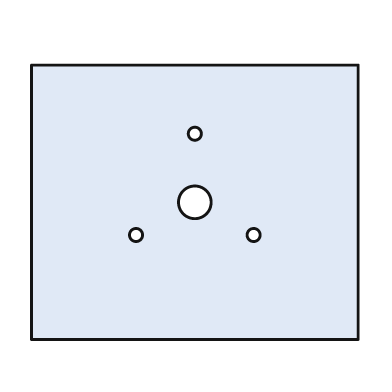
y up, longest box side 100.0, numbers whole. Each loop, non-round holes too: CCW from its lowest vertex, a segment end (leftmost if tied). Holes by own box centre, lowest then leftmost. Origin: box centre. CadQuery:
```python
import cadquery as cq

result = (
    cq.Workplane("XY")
    .moveTo(-50.0, -42.0)
    .lineTo(50.0, -42.0)
    .lineTo(50.0, 42.0)
    .lineTo(-50.0, 42.0)
    .close()
    .moveTo(-18.0, -10.0)
    .circle(2.0)
    .moveTo(18.0, -10.0)
    .circle(2.0)
    .moveTo(0.0, 0.0)
    .circle(5.0)
    .moveTo(0.0, 21.0)
    .circle(2.0)
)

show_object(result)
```